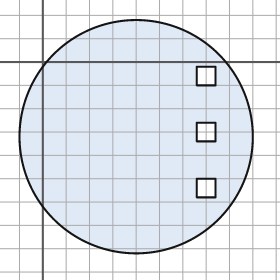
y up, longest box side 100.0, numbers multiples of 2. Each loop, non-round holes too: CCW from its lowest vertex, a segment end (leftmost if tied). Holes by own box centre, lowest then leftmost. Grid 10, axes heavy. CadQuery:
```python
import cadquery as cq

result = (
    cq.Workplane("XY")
    .moveTo(40.0, -32.0)
    .circle(50.0)
    .moveTo(66.0, -58.0)
    .lineTo(74.0, -58.0)
    .lineTo(74.0, -50.0)
    .lineTo(66.0, -50.0)
    .close()
    .moveTo(66.0, -34.0)
    .lineTo(74.0, -34.0)
    .lineTo(74.0, -26.0)
    .lineTo(66.0, -26.0)
    .close()
    .moveTo(66.0, -10.0)
    .lineTo(74.0, -10.0)
    .lineTo(74.0, -2.0)
    .lineTo(66.0, -2.0)
    .close()
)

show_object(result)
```